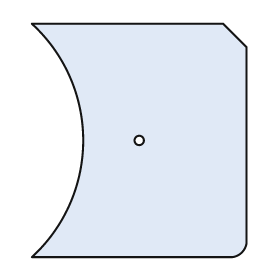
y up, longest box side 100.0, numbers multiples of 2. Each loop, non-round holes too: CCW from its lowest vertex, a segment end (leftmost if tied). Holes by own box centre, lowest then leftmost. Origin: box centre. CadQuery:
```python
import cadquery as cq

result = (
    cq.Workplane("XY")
    .moveTo(-46.0, -50.0)
    .lineTo(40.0, -50.0)
    .threePointArc((44.0, -48.0), (46.0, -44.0))
    .lineTo(46.0, 40.0)
    .lineTo(36.0, 50.0)
    .lineTo(-46.0, 50.0)
    .threePointArc((-24.0, 0.0), (-46.0, -50.0))
    .close()
    .moveTo(0.0, 0.0)
    .circle(2.0)
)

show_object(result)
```